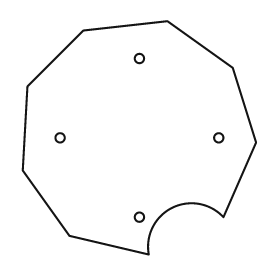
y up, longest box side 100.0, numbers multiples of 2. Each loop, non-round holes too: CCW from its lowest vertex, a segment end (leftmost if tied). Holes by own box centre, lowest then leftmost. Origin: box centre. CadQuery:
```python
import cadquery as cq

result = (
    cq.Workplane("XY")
    .moveTo(4.0, -50.0)
    .threePointArc((14.0, -30.0), (36.0, -34.0))
    .lineTo(50.0, -2.0)
    .lineTo(40.0, 30.0)
    .lineTo(12.0, 50.0)
    .lineTo(-24.0, 46.0)
    .lineTo(-48.0, 22.0)
    .lineTo(-50.0, -14.0)
    .lineTo(-30.0, -42.0)
    .close()
    .moveTo(0.0, -34.0)
    .circle(2.0)
    .moveTo(-34.0, 0.0)
    .circle(2.0)
    .moveTo(34.0, 0.0)
    .circle(2.0)
    .moveTo(0.0, 34.0)
    .circle(2.0)
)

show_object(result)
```